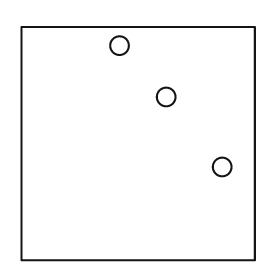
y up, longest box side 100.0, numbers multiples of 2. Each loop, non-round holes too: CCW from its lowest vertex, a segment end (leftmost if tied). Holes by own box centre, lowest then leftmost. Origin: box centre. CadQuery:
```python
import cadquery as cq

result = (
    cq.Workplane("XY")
    .moveTo(-50.0, -50.0)
    .lineTo(50.0, -50.0)
    .lineTo(50.0, 50.0)
    .lineTo(-50.0, 50.0)
    .close()
    .moveTo(36.0, -10.0)
    .circle(4.0)
    .moveTo(12.0, 20.0)
    .circle(4.0)
    .moveTo(-8.0, 42.0)
    .circle(4.0)
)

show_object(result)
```